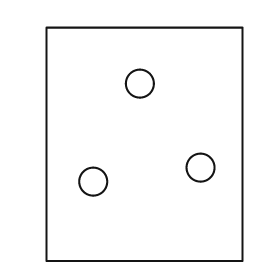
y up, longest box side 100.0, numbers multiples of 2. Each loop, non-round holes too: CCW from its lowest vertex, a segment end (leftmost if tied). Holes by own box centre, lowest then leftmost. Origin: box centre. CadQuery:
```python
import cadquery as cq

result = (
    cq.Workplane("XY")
    .moveTo(-42.0, -50.0)
    .lineTo(42.0, -50.0)
    .lineTo(42.0, 50.0)
    .lineTo(-42.0, 50.0)
    .close()
    .moveTo(-22.0, -16.0)
    .circle(6.0)
    .moveTo(24.0, -10.0)
    .circle(6.0)
    .moveTo(-2.0, 26.0)
    .circle(6.0)
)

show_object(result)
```